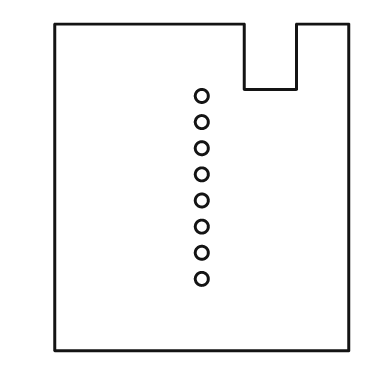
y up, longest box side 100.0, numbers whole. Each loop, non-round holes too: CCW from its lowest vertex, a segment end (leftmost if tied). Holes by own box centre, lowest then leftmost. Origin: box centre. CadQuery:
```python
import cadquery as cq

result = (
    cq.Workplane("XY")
    .moveTo(-45.0, -50.0)
    .lineTo(45.0, -50.0)
    .lineTo(45.0, 50.0)
    .lineTo(29.0, 50.0)
    .lineTo(29.0, 30.0)
    .lineTo(13.0, 30.0)
    .lineTo(13.0, 50.0)
    .lineTo(-45.0, 50.0)
    .close()
    .moveTo(0.0, -28.0)
    .circle(2.0)
    .moveTo(0.0, -20.0)
    .circle(2.0)
    .moveTo(0.0, -12.0)
    .circle(2.0)
    .moveTo(0.0, -4.0)
    .circle(2.0)
    .moveTo(0.0, 4.0)
    .circle(2.0)
    .moveTo(0.0, 12.0)
    .circle(2.0)
    .moveTo(0.0, 20.0)
    .circle(2.0)
    .moveTo(0.0, 28.0)
    .circle(2.0)
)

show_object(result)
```